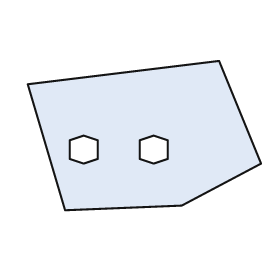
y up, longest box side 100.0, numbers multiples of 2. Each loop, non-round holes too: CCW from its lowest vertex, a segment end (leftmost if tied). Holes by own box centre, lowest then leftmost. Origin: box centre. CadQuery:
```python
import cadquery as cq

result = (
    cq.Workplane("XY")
    .moveTo(-34.0, -32.0)
    .lineTo(16.0, -30.0)
    .lineTo(50.0, -12.0)
    .lineTo(32.0, 32.0)
    .lineTo(-50.0, 22.0)
    .close()
    .moveTo(-26.0, -12.0)
    .lineTo(-20.0, -10.0)
    .lineTo(-20.0, -2.0)
    .lineTo(-26.0, 0.0)
    .lineTo(-32.0, -2.0)
    .lineTo(-32.0, -10.0)
    .close()
    .moveTo(4.0, -12.0)
    .lineTo(10.0, -10.0)
    .lineTo(10.0, -2.0)
    .lineTo(4.0, 0.0)
    .lineTo(-2.0, -2.0)
    .lineTo(-2.0, -10.0)
    .close()
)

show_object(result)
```